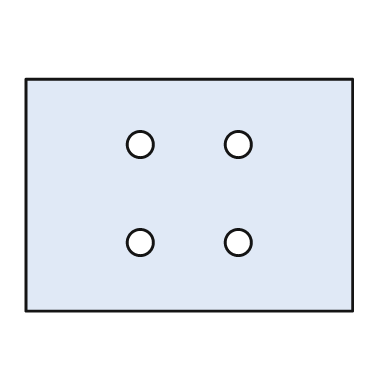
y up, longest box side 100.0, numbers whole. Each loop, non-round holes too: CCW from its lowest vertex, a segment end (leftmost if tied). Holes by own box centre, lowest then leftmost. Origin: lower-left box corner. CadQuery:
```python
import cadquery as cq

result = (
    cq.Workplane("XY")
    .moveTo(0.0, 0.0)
    .lineTo(100.0, 0.0)
    .lineTo(100.0, 71.0)
    .lineTo(0.0, 71.0)
    .close()
    .moveTo(35.0, 21.0)
    .circle(4.0)
    .moveTo(65.0, 21.0)
    .circle(4.0)
    .moveTo(35.0, 51.0)
    .circle(4.0)
    .moveTo(65.0, 51.0)
    .circle(4.0)
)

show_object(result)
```